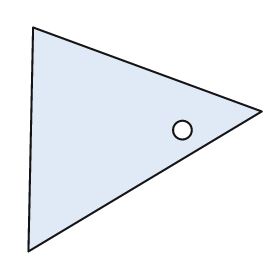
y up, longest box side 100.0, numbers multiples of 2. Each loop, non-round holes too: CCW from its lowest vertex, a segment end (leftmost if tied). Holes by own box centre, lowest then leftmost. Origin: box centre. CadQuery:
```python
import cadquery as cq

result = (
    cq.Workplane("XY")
    .moveTo(-50.0, -48.0)
    .lineTo(50.0, 12.0)
    .lineTo(-48.0, 48.0)
    .close()
    .moveTo(16.0, 4.0)
    .circle(4.0)
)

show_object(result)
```